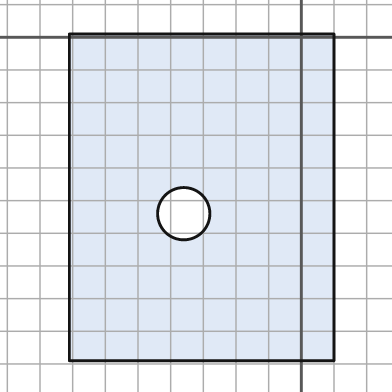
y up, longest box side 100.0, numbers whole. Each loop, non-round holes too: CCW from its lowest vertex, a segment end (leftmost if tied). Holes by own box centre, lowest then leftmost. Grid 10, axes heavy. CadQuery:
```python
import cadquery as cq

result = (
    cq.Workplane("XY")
    .moveTo(-71.0, -99.0)
    .lineTo(10.0, -99.0)
    .lineTo(10.0, 1.0)
    .lineTo(-71.0, 1.0)
    .close()
    .moveTo(-36.0, -54.0)
    .circle(8.0)
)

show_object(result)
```